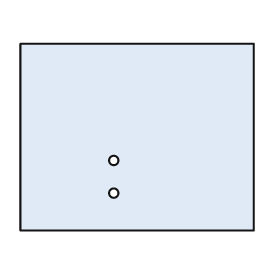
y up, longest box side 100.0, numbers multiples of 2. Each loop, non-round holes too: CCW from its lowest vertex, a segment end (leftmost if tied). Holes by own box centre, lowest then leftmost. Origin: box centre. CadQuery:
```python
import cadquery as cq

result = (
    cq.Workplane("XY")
    .moveTo(-50.0, -40.0)
    .lineTo(50.0, -40.0)
    .lineTo(50.0, 40.0)
    .lineTo(-50.0, 40.0)
    .close()
    .moveTo(-10.0, -24.0)
    .circle(2.0)
    .moveTo(-10.0, -10.0)
    .circle(2.0)
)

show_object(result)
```